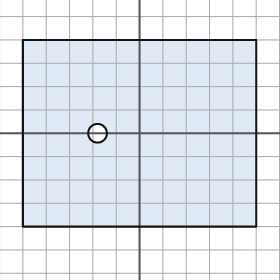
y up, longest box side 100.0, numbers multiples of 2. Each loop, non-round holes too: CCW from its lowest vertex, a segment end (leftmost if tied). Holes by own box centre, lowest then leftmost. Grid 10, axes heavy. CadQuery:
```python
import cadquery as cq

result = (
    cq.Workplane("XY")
    .moveTo(-50.0, -40.0)
    .lineTo(50.0, -40.0)
    .lineTo(50.0, 40.0)
    .lineTo(-50.0, 40.0)
    .close()
    .moveTo(-18.0, 0.0)
    .circle(4.0)
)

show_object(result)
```